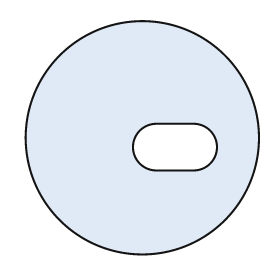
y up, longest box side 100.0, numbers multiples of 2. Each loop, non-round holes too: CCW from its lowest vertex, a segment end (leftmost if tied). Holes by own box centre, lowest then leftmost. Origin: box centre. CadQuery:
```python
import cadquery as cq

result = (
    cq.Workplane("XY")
    .moveTo(0.0, 0.0)
    .circle(50.0)
    .moveTo(6.0, -14.0)
    .lineTo(22.0, -14.0)
    .threePointArc((32.0, -4.0), (22.0, 6.0))
    .lineTo(6.0, 6.0)
    .threePointArc((-4.0, -4.0), (6.0, -14.0))
    .close()
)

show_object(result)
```